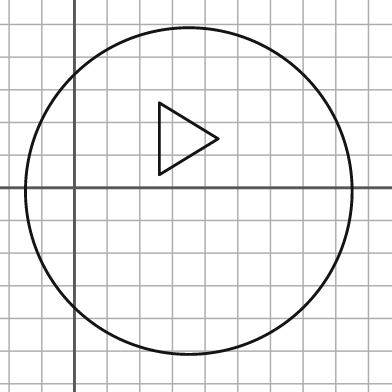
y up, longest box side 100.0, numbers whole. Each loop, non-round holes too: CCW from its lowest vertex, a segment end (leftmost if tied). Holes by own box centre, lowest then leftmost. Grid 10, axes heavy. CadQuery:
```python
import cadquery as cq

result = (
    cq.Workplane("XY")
    .moveTo(35.0, -1.0)
    .circle(50.0)
    .moveTo(26.0, 4.0)
    .lineTo(44.0, 15.0)
    .lineTo(26.0, 26.0)
    .close()
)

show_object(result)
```